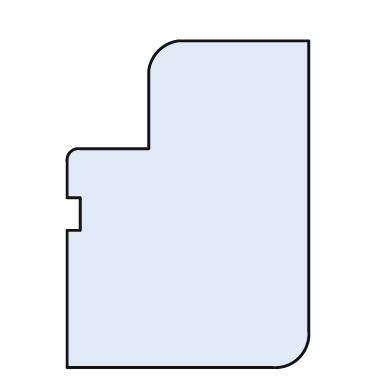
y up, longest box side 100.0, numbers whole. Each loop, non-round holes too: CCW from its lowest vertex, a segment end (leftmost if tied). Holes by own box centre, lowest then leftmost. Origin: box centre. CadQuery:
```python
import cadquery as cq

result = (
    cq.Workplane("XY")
    .moveTo(-37.0, -50.0)
    .lineTo(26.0, -50.0)
    .threePointArc((34.0, -47.0), (37.0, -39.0))
    .lineTo(37.0, 50.0)
    .lineTo(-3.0, 50.0)
    .threePointArc((-9.0, 47.0), (-12.0, 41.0))
    .lineTo(-12.0, 17.0)
    .lineTo(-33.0, 17.0)
    .threePointArc((-36.0, 16.0), (-37.0, 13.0))
    .lineTo(-37.0, 2.0)
    .lineTo(-33.0, 2.0)
    .lineTo(-33.0, -8.0)
    .lineTo(-37.0, -8.0)
    .close()
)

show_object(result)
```